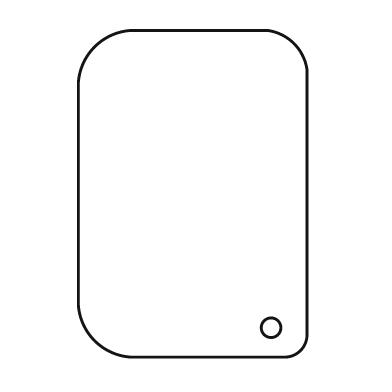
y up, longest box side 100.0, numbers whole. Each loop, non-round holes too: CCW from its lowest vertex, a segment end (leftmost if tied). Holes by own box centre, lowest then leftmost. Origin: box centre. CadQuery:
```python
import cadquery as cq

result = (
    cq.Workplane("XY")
    .moveTo(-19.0, -50.0)
    .lineTo(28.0, -50.0)
    .threePointArc((33.0, -48.0), (35.0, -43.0))
    .lineTo(35.0, 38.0)
    .threePointArc((31.0, 46.0), (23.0, 50.0))
    .lineTo(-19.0, 50.0)
    .threePointArc((-30.0, 45.0), (-35.0, 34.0))
    .lineTo(-35.0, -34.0)
    .threePointArc((-30.0, -45.0), (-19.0, -50.0))
    .close()
    .moveTo(24.0, -41.0)
    .circle(3.0)
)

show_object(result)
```